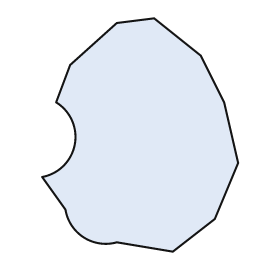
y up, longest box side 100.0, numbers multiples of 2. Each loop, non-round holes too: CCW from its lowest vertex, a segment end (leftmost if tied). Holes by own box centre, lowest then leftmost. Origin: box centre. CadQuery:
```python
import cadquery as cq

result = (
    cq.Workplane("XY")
    .moveTo(14.0, -50.0)
    .lineTo(32.0, -36.0)
    .lineTo(42.0, -12.0)
    .lineTo(36.0, 14.0)
    .lineTo(26.0, 34.0)
    .lineTo(6.0, 50.0)
    .lineTo(-10.0, 48.0)
    .lineTo(-30.0, 30.0)
    .lineTo(-36.0, 14.0)
    .threePointArc((-28.0, -4.0), (-42.0, -18.0))
    .lineTo(-32.0, -32.0)
    .threePointArc((-24.0, -44.0), (-10.0, -46.0))
    .close()
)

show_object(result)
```